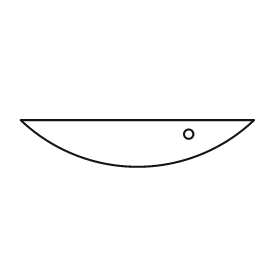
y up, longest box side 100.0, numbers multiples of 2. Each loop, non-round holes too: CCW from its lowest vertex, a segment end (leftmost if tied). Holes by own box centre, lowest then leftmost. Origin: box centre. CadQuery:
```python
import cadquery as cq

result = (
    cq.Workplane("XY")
    .moveTo(-50.0, 10.0)
    .threePointArc((0.0, -10.0), (50.0, 10.0))
    .close()
    .moveTo(22.0, 4.0)
    .circle(2.0)
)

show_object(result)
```